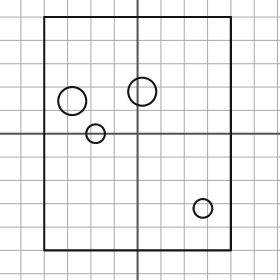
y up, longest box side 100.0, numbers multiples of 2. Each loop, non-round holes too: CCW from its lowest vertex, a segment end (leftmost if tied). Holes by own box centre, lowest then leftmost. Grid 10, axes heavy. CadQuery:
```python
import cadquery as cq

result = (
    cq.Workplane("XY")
    .moveTo(-40.0, -50.0)
    .lineTo(40.0, -50.0)
    .lineTo(40.0, 50.0)
    .lineTo(-40.0, 50.0)
    .close()
    .moveTo(28.0, -32.0)
    .circle(4.0)
    .moveTo(-18.0, 0.0)
    .circle(4.0)
    .moveTo(-28.0, 14.0)
    .circle(6.0)
    .moveTo(2.0, 18.0)
    .circle(6.0)
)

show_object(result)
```